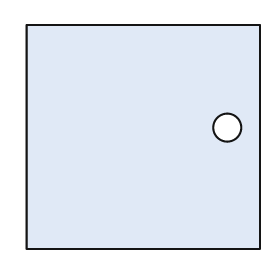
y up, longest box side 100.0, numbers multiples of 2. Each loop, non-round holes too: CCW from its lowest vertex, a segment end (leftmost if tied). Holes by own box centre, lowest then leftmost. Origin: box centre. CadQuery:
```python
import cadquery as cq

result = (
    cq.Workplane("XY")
    .moveTo(-50.0, -48.0)
    .lineTo(50.0, -48.0)
    .lineTo(50.0, 48.0)
    .lineTo(-50.0, 48.0)
    .close()
    .moveTo(36.0, 4.0)
    .circle(6.0)
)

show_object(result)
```